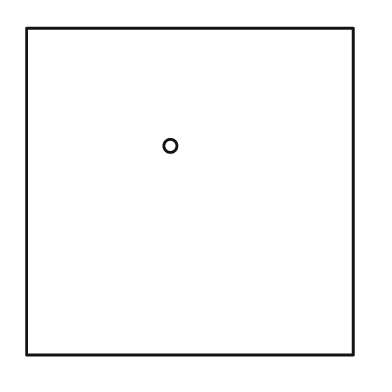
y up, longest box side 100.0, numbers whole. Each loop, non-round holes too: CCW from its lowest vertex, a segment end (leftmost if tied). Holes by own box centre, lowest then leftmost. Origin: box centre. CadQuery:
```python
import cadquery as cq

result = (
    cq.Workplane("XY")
    .moveTo(-50.0, -50.0)
    .lineTo(50.0, -50.0)
    .lineTo(50.0, 50.0)
    .lineTo(-50.0, 50.0)
    .close()
    .moveTo(-6.0, 14.0)
    .circle(2.0)
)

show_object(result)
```